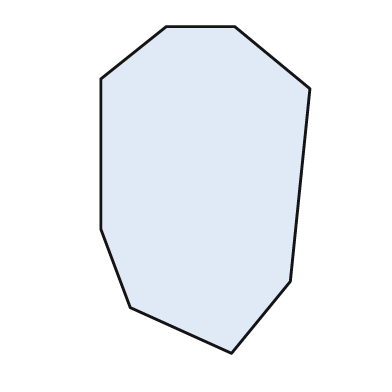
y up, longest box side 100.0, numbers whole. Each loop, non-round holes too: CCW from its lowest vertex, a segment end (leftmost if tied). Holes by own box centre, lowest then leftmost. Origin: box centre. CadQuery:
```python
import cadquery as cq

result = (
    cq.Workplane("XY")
    .moveTo(8.0, -50.0)
    .lineTo(26.0, -28.0)
    .lineTo(32.0, 31.0)
    .lineTo(9.0, 50.0)
    .lineTo(-12.0, 50.0)
    .lineTo(-32.0, 34.0)
    .lineTo(-32.0, -12.0)
    .lineTo(-23.0, -36.0)
    .close()
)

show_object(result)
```